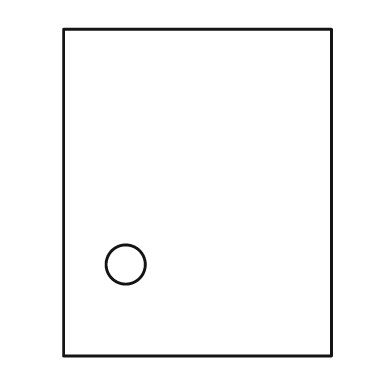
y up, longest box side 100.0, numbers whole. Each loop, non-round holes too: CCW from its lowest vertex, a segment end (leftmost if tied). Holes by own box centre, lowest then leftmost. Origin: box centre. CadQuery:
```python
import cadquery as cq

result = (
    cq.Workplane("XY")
    .moveTo(-41.0, -50.0)
    .lineTo(41.0, -50.0)
    .lineTo(41.0, 50.0)
    .lineTo(-41.0, 50.0)
    .close()
    .moveTo(-22.0, -22.0)
    .circle(6.0)
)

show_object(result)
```